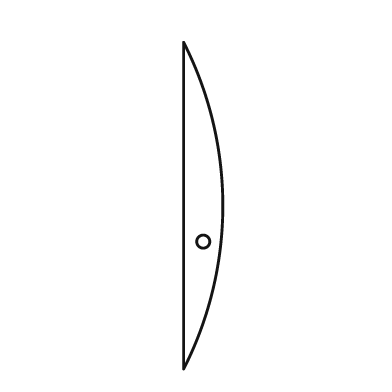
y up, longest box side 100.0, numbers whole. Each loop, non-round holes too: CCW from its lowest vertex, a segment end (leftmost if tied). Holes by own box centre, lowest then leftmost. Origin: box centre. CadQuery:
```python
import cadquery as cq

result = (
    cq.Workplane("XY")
    .moveTo(-6.0, -50.0)
    .threePointArc((6.0, 0.0), (-6.0, 50.0))
    .close()
    .moveTo(0.0, -11.0)
    .circle(2.0)
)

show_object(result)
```